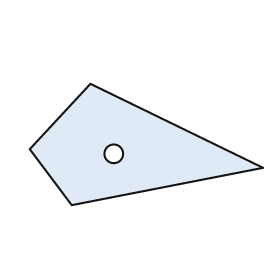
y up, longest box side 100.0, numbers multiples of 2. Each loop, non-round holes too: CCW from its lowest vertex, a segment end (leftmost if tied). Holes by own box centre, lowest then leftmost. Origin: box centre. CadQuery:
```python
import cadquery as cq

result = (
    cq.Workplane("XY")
    .moveTo(-32.0, -26.0)
    .lineTo(50.0, -10.0)
    .lineTo(-24.0, 26.0)
    .lineTo(-50.0, -2.0)
    .close()
    .moveTo(-14.0, -4.0)
    .circle(4.0)
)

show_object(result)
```